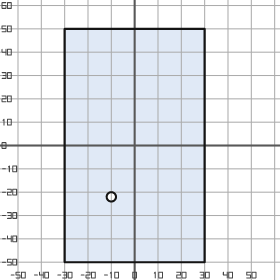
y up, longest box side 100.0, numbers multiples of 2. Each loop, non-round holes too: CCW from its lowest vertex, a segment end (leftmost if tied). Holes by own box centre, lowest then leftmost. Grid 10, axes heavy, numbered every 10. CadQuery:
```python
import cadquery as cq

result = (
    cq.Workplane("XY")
    .moveTo(-30.0, -50.0)
    .lineTo(30.0, -50.0)
    .lineTo(30.0, 50.0)
    .lineTo(-30.0, 50.0)
    .close()
    .moveTo(-10.0, -22.0)
    .circle(2.0)
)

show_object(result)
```